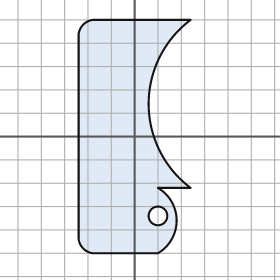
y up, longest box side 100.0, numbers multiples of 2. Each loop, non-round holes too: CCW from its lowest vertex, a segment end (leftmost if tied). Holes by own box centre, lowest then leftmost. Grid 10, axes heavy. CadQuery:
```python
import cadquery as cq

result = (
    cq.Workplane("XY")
    .moveTo(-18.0, -50.0)
    .lineTo(10.0, -50.0)
    .threePointArc((18.0, -36.0), (10.0, -22.0))
    .lineTo(24.0, -22.0)
    .threePointArc((6.0, 14.0), (24.0, 50.0))
    .lineTo(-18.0, 50.0)
    .threePointArc((-22.0, 48.0), (-24.0, 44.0))
    .lineTo(-24.0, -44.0)
    .threePointArc((-22.0, -48.0), (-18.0, -50.0))
    .close()
    .moveTo(10.0, -34.0)
    .circle(4.0)
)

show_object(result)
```